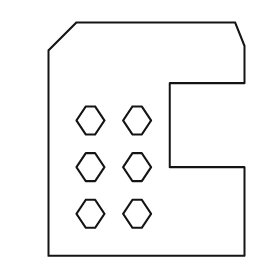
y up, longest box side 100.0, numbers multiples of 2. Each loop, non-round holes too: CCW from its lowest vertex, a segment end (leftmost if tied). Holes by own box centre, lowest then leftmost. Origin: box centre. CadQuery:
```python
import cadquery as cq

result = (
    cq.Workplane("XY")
    .moveTo(-42.0, -50.0)
    .lineTo(42.0, -50.0)
    .lineTo(42.0, -12.0)
    .lineTo(10.0, -12.0)
    .lineTo(10.0, 24.0)
    .lineTo(42.0, 24.0)
    .lineTo(42.0, 40.0)
    .lineTo(38.0, 50.0)
    .lineTo(-30.0, 50.0)
    .lineTo(-42.0, 38.0)
    .close()
    .moveTo(-26.0, -38.0)
    .lineTo(-22.0, -38.0)
    .lineTo(-18.0, -32.0)
    .lineTo(-22.0, -26.0)
    .lineTo(-26.0, -26.0)
    .lineTo(-30.0, -32.0)
    .close()
    .moveTo(-6.0, -38.0)
    .lineTo(-2.0, -38.0)
    .lineTo(2.0, -32.0)
    .lineTo(-2.0, -26.0)
    .lineTo(-6.0, -26.0)
    .lineTo(-10.0, -32.0)
    .close()
    .moveTo(-26.0, -18.0)
    .lineTo(-22.0, -18.0)
    .lineTo(-18.0, -12.0)
    .lineTo(-22.0, -6.0)
    .lineTo(-26.0, -6.0)
    .lineTo(-30.0, -12.0)
    .close()
    .moveTo(-6.0, -18.0)
    .lineTo(-2.0, -18.0)
    .lineTo(2.0, -12.0)
    .lineTo(-2.0, -6.0)
    .lineTo(-6.0, -6.0)
    .lineTo(-10.0, -12.0)
    .close()
    .moveTo(-26.0, 2.0)
    .lineTo(-22.0, 2.0)
    .lineTo(-18.0, 8.0)
    .lineTo(-22.0, 14.0)
    .lineTo(-26.0, 14.0)
    .lineTo(-30.0, 8.0)
    .close()
    .moveTo(-6.0, 2.0)
    .lineTo(-2.0, 2.0)
    .lineTo(2.0, 8.0)
    .lineTo(-2.0, 14.0)
    .lineTo(-6.0, 14.0)
    .lineTo(-10.0, 8.0)
    .close()
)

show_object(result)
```